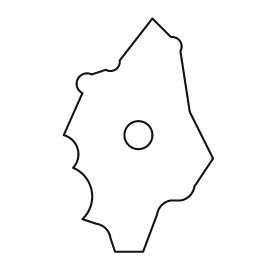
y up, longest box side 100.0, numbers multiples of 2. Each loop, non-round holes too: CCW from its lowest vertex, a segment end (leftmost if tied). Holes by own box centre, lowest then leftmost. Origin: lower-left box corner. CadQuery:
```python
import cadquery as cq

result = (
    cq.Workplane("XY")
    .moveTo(22.0, 0.0)
    .lineTo(34.0, 0.0)
    .lineTo(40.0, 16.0)
    .threePointArc((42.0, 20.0), (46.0, 22.0))
    .lineTo(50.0, 22.0)
    .threePointArc((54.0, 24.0), (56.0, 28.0))
    .lineTo(64.0, 40.0)
    .lineTo(54.0, 60.0)
    .lineTo(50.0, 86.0)
    .threePointArc((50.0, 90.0), (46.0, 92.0))
    .lineTo(38.0, 100.0)
    .lineTo(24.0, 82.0)
    .threePointArc((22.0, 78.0), (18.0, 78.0))
    .lineTo(12.0, 76.0)
    .threePointArc((6.0, 74.0), (8.0, 68.0))
    .lineTo(0.0, 50.0)
    .threePointArc((6.0, 44.0), (4.0, 36.0))
    .threePointArc((12.0, 26.0), (8.0, 14.0))
    .lineTo(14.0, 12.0)
    .threePointArc((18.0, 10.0), (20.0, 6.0))
    .close()
    .moveTo(32.0, 50.0)
    .circle(6.0)
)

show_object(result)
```